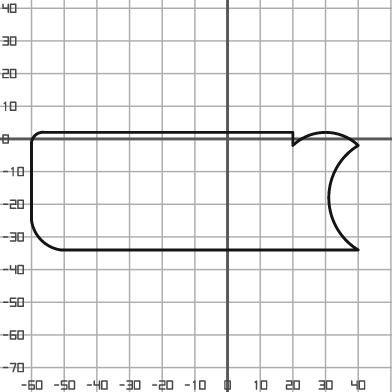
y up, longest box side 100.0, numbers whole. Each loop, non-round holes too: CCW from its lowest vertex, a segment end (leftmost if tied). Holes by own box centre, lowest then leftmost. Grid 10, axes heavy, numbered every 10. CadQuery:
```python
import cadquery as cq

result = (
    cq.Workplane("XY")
    .moveTo(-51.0, -34.0)
    .lineTo(40.0, -34.0)
    .threePointArc((31.0, -18.0), (40.0, -2.0))
    .threePointArc((30.0, 2.0), (20.0, -2.0))
    .lineTo(20.0, 2.0)
    .lineTo(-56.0, 2.0)
    .threePointArc((-59.0, 1.0), (-60.0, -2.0))
    .lineTo(-60.0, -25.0)
    .threePointArc((-57.0, -31.0), (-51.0, -34.0))
    .close()
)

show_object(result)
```